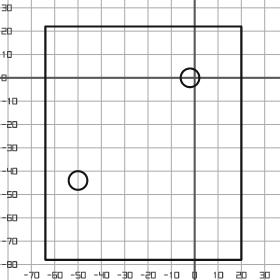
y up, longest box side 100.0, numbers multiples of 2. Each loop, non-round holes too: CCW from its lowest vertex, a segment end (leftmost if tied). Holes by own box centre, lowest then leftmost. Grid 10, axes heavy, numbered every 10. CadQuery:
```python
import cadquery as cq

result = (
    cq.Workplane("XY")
    .moveTo(-64.0, -78.0)
    .lineTo(20.0, -78.0)
    .lineTo(20.0, 22.0)
    .lineTo(-64.0, 22.0)
    .close()
    .moveTo(-50.0, -44.0)
    .circle(4.0)
    .moveTo(-2.0, 0.0)
    .circle(4.0)
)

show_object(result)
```